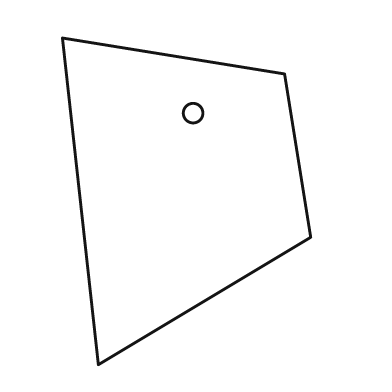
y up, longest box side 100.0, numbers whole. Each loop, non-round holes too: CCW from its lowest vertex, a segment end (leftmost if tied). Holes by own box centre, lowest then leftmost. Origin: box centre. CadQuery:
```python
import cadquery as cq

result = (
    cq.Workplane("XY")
    .moveTo(-27.0, -50.0)
    .lineTo(38.0, -11.0)
    .lineTo(30.0, 39.0)
    .lineTo(-38.0, 50.0)
    .close()
    .moveTo(2.0, 27.0)
    .circle(3.0)
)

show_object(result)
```